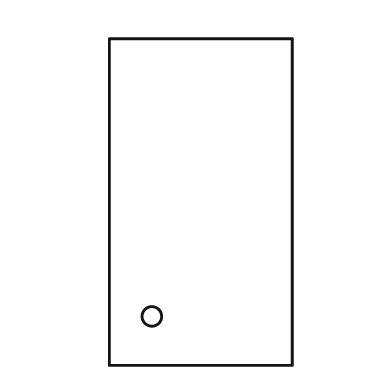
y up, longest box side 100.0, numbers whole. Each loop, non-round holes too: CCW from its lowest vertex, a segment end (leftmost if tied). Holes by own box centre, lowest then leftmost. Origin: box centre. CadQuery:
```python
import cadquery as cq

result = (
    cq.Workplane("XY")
    .moveTo(-28.0, -50.0)
    .lineTo(28.0, -50.0)
    .lineTo(28.0, 50.0)
    .lineTo(-28.0, 50.0)
    .close()
    .moveTo(-15.0, -35.0)
    .circle(3.0)
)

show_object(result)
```